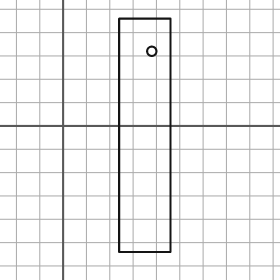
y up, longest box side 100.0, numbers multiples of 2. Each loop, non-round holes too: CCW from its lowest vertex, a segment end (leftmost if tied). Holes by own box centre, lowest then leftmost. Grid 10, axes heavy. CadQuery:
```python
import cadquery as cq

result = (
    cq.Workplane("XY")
    .moveTo(24.0, -54.0)
    .lineTo(46.0, -54.0)
    .lineTo(46.0, 46.0)
    .lineTo(24.0, 46.0)
    .close()
    .moveTo(38.0, 32.0)
    .circle(2.0)
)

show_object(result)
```